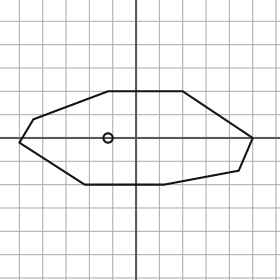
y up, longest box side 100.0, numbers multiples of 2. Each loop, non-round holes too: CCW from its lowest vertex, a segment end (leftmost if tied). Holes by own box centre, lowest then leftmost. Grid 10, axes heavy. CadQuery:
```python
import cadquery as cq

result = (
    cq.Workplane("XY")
    .moveTo(-22.0, -20.0)
    .lineTo(12.0, -20.0)
    .lineTo(44.0, -14.0)
    .lineTo(50.0, 0.0)
    .lineTo(20.0, 20.0)
    .lineTo(-12.0, 20.0)
    .lineTo(-44.0, 8.0)
    .lineTo(-50.0, -2.0)
    .close()
    .moveTo(-12.0, 0.0)
    .circle(2.0)
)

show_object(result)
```